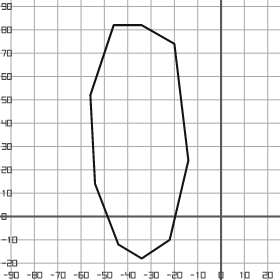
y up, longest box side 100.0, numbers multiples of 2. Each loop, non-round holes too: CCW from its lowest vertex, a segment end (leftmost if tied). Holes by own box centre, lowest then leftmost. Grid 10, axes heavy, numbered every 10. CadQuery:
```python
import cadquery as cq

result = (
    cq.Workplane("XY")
    .moveTo(-34.0, -18.0)
    .lineTo(-22.0, -10.0)
    .lineTo(-14.0, 24.0)
    .lineTo(-20.0, 74.0)
    .lineTo(-34.0, 82.0)
    .lineTo(-46.0, 82.0)
    .lineTo(-56.0, 52.0)
    .lineTo(-54.0, 14.0)
    .lineTo(-44.0, -12.0)
    .close()
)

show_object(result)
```